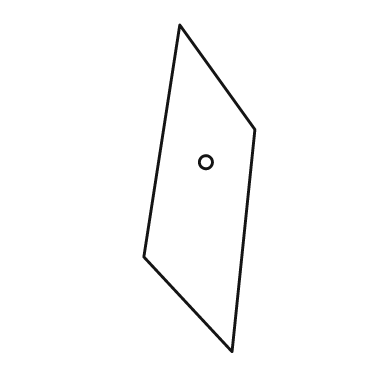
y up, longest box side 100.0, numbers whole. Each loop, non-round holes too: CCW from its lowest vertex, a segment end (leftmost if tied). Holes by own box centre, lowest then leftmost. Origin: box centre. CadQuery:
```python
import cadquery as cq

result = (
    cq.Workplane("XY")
    .moveTo(10.0, -50.0)
    .lineTo(17.0, 18.0)
    .lineTo(-6.0, 50.0)
    .lineTo(-17.0, -21.0)
    .close()
    .moveTo(2.0, 8.0)
    .circle(2.0)
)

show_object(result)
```